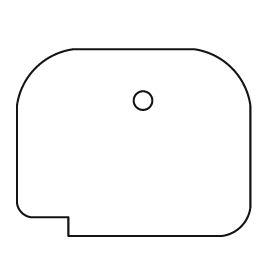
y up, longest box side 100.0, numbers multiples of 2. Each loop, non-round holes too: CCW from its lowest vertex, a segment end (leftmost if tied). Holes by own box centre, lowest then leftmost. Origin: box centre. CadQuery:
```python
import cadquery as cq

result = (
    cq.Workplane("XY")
    .moveTo(-28.0, -40.0)
    .lineTo(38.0, -40.0)
    .threePointArc((46.0, -36.0), (50.0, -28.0))
    .lineTo(50.0, 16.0)
    .threePointArc((42.0, 32.0), (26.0, 40.0))
    .lineTo(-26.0, 40.0)
    .threePointArc((-42.0, 32.0), (-50.0, 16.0))
    .lineTo(-50.0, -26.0)
    .threePointArc((-48.0, -30.0), (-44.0, -32.0))
    .lineTo(-28.0, -32.0)
    .close()
    .moveTo(4.0, 18.0)
    .circle(4.0)
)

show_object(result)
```